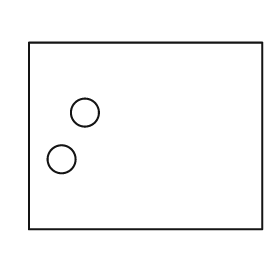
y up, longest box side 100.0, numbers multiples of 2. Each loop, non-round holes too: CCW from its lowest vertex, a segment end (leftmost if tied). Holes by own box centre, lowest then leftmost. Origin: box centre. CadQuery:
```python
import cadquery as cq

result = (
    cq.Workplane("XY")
    .moveTo(-50.0, -40.0)
    .lineTo(50.0, -40.0)
    .lineTo(50.0, 40.0)
    .lineTo(-50.0, 40.0)
    .close()
    .moveTo(-36.0, -10.0)
    .circle(6.0)
    .moveTo(-26.0, 10.0)
    .circle(6.0)
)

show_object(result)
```